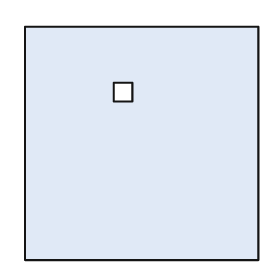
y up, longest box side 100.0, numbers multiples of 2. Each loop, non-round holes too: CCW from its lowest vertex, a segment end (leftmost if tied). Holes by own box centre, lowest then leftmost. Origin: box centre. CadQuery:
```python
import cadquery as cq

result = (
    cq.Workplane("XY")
    .moveTo(-50.0, -50.0)
    .lineTo(50.0, -50.0)
    .lineTo(50.0, 50.0)
    .lineTo(-50.0, 50.0)
    .close()
    .moveTo(-12.0, 18.0)
    .lineTo(-4.0, 18.0)
    .lineTo(-4.0, 26.0)
    .lineTo(-12.0, 26.0)
    .close()
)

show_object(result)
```